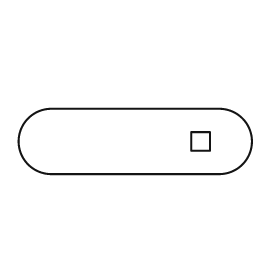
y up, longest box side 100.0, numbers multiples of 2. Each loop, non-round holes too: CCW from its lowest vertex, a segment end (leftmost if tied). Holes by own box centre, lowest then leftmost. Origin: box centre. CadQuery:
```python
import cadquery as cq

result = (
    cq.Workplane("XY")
    .moveTo(-36.0, -14.0)
    .lineTo(36.0, -14.0)
    .threePointArc((50.0, 0.0), (36.0, 14.0))
    .lineTo(-36.0, 14.0)
    .threePointArc((-50.0, 0.0), (-36.0, -14.0))
    .close()
    .moveTo(24.0, -4.0)
    .lineTo(32.0, -4.0)
    .lineTo(32.0, 4.0)
    .lineTo(24.0, 4.0)
    .close()
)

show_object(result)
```